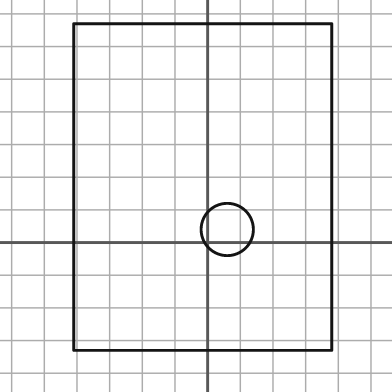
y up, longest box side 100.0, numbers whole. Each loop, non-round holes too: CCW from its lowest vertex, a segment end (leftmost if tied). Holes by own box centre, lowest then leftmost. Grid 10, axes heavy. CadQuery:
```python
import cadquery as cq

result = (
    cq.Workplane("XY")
    .moveTo(-41.0, -33.0)
    .lineTo(38.0, -33.0)
    .lineTo(38.0, 67.0)
    .lineTo(-41.0, 67.0)
    .close()
    .moveTo(6.0, 4.0)
    .circle(8.0)
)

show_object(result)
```